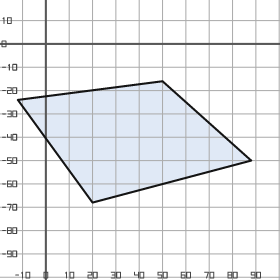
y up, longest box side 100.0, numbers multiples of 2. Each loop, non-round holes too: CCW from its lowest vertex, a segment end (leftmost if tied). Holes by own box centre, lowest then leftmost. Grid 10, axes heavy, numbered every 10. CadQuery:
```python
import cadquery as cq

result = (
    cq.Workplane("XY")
    .moveTo(20.0, -68.0)
    .lineTo(88.0, -50.0)
    .lineTo(50.0, -16.0)
    .lineTo(-12.0, -24.0)
    .close()
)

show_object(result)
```